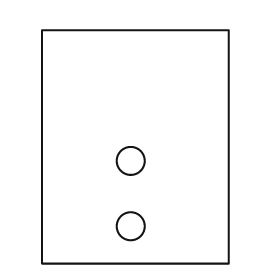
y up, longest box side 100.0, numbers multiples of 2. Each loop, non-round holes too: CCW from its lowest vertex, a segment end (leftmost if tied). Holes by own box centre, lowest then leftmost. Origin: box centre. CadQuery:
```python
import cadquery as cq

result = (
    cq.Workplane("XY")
    .moveTo(-40.0, -50.0)
    .lineTo(40.0, -50.0)
    .lineTo(40.0, 50.0)
    .lineTo(-40.0, 50.0)
    .close()
    .moveTo(-2.0, -34.0)
    .circle(6.0)
    .moveTo(-2.0, -6.0)
    .circle(6.0)
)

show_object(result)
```